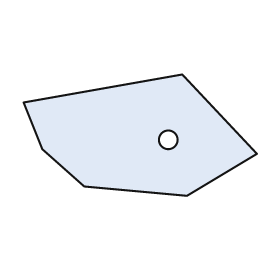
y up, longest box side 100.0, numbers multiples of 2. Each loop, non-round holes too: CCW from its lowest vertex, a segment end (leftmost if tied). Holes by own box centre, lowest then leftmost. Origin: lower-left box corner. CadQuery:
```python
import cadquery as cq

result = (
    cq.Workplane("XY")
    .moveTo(70.0, 0.0)
    .lineTo(100.0, 18.0)
    .lineTo(68.0, 52.0)
    .lineTo(0.0, 40.0)
    .lineTo(8.0, 20.0)
    .lineTo(26.0, 4.0)
    .close()
    .moveTo(62.0, 24.0)
    .circle(4.0)
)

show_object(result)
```